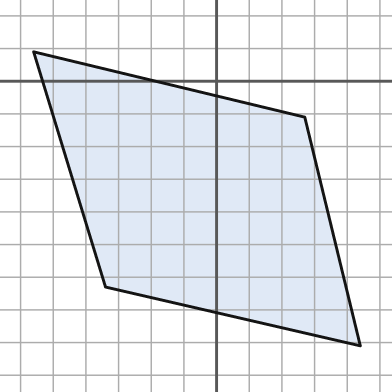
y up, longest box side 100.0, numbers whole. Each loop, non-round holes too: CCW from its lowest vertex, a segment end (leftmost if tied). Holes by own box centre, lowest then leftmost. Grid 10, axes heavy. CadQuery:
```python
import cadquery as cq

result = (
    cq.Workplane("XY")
    .moveTo(44.0, -81.0)
    .lineTo(27.0, -11.0)
    .lineTo(-56.0, 9.0)
    .lineTo(-34.0, -63.0)
    .close()
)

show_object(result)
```